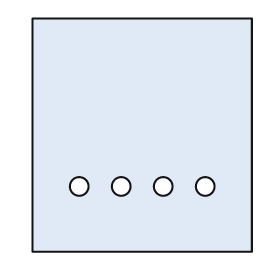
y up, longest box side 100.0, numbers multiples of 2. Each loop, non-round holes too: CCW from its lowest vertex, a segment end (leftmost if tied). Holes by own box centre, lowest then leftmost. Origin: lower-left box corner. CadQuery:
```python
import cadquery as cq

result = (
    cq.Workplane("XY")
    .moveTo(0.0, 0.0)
    .lineTo(94.0, 0.0)
    .lineTo(94.0, 100.0)
    .lineTo(0.0, 100.0)
    .close()
    .moveTo(20.0, 28.0)
    .circle(4.0)
    .moveTo(38.0, 28.0)
    .circle(4.0)
    .moveTo(56.0, 28.0)
    .circle(4.0)
    .moveTo(74.0, 28.0)
    .circle(4.0)
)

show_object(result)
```